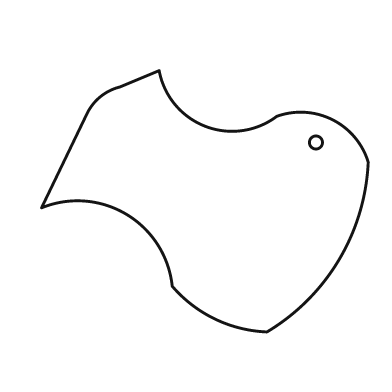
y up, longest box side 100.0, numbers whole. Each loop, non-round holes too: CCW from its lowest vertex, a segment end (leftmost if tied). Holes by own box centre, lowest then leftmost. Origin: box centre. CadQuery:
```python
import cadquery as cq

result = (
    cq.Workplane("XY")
    .moveTo(19.0, -40.0)
    .threePointArc((41.0, -18.0), (50.0, 12.0))
    .threePointArc((39.0, 25.0), (22.0, 26.0))
    .threePointArc((0.0, 23.0), (-14.0, 40.0))
    .lineTo(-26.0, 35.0)
    .threePointArc((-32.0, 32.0), (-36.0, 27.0))
    .lineTo(-50.0, -2.0)
    .threePointArc((-24.0, -4.0), (-10.0, -26.0))
    .threePointArc((3.0, -36.0), (19.0, -40.0))
    .close()
    .moveTo(34.0, 18.0)
    .circle(2.0)
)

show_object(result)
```